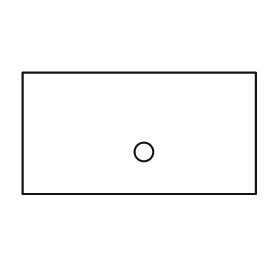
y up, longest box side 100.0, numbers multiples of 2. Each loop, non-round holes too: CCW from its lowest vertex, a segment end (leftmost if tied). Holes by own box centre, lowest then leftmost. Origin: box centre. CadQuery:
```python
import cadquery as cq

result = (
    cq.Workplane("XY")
    .moveTo(-50.0, -26.0)
    .lineTo(50.0, -26.0)
    .lineTo(50.0, 26.0)
    .lineTo(-50.0, 26.0)
    .close()
    .moveTo(2.0, -8.0)
    .circle(4.0)
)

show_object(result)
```